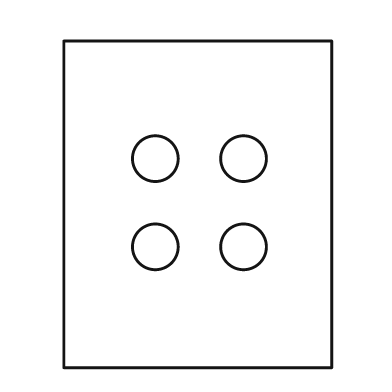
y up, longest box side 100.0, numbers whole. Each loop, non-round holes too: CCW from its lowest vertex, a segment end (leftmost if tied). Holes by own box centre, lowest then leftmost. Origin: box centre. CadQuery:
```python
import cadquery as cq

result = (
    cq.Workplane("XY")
    .moveTo(-41.0, -50.0)
    .lineTo(41.0, -50.0)
    .lineTo(41.0, 50.0)
    .lineTo(-41.0, 50.0)
    .close()
    .moveTo(-13.0, -13.0)
    .circle(7.0)
    .moveTo(14.0, -13.0)
    .circle(7.0)
    .moveTo(-13.0, 14.0)
    .circle(7.0)
    .moveTo(14.0, 14.0)
    .circle(7.0)
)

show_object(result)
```